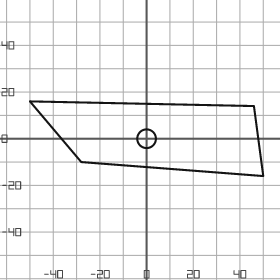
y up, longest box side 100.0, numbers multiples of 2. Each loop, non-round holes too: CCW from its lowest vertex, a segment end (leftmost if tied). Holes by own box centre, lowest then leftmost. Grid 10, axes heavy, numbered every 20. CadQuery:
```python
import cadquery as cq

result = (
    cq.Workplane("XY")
    .moveTo(50.0, -16.0)
    .lineTo(46.0, 14.0)
    .lineTo(-50.0, 16.0)
    .lineTo(-28.0, -10.0)
    .close()
    .moveTo(0.0, 0.0)
    .circle(4.0)
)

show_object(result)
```